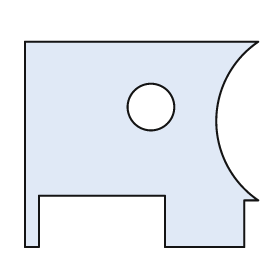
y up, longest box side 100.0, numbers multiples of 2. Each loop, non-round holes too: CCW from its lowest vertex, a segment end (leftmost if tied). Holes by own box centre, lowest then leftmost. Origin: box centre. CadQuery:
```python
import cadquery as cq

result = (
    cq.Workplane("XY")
    .moveTo(-50.0, -44.0)
    .lineTo(-44.0, -44.0)
    .lineTo(-44.0, -22.0)
    .lineTo(10.0, -22.0)
    .lineTo(10.0, -44.0)
    .lineTo(44.0, -44.0)
    .lineTo(44.0, -24.0)
    .lineTo(50.0, -24.0)
    .threePointArc((32.0, 10.0), (50.0, 44.0))
    .lineTo(-50.0, 44.0)
    .close()
    .moveTo(4.0, 16.0)
    .circle(10.0)
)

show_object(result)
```